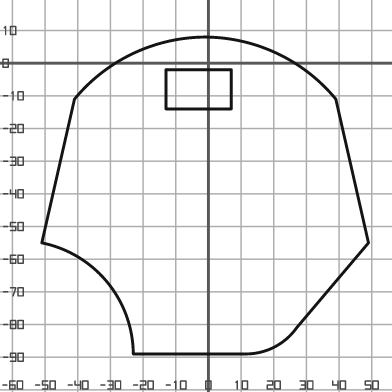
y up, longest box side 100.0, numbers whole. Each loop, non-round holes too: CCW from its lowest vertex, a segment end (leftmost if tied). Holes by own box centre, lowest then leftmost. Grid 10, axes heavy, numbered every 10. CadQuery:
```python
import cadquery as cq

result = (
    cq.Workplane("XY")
    .moveTo(-23.0, -89.0)
    .lineTo(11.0, -89.0)
    .threePointArc((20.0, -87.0), (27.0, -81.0))
    .lineTo(49.0, -55.0)
    .lineTo(39.0, -11.0)
    .threePointArc((21.0, 3.0), (-1.0, 8.0))
    .threePointArc((-23.0, 3.0), (-41.0, -11.0))
    .lineTo(-51.0, -55.0)
    .threePointArc((-31.0, -67.0), (-23.0, -89.0))
    .close()
    .moveTo(-13.0, -14.0)
    .lineTo(7.0, -14.0)
    .lineTo(7.0, -2.0)
    .lineTo(-13.0, -2.0)
    .close()
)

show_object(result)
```